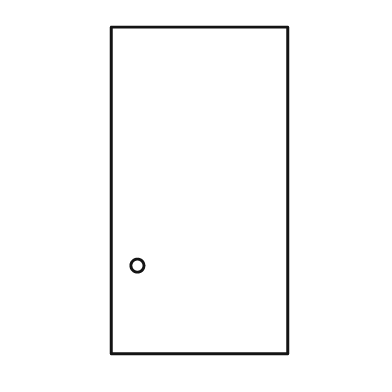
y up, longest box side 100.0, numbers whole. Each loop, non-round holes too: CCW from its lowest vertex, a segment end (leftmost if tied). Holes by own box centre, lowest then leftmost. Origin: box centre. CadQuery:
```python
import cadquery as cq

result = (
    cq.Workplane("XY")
    .moveTo(-27.0, -50.0)
    .lineTo(27.0, -50.0)
    .lineTo(27.0, 50.0)
    .lineTo(-27.0, 50.0)
    .close()
    .moveTo(-19.0, -23.0)
    .circle(2.0)
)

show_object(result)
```